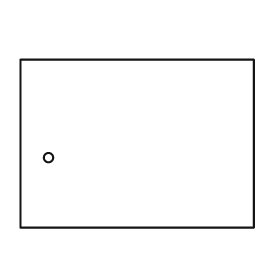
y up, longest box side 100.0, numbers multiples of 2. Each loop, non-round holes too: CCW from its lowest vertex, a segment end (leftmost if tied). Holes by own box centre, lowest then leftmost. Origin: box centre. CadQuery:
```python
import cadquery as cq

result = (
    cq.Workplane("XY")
    .moveTo(-50.0, -36.0)
    .lineTo(50.0, -36.0)
    .lineTo(50.0, 36.0)
    .lineTo(-50.0, 36.0)
    .close()
    .moveTo(-38.0, -6.0)
    .circle(2.0)
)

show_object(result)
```